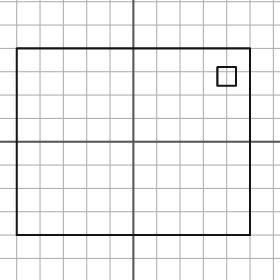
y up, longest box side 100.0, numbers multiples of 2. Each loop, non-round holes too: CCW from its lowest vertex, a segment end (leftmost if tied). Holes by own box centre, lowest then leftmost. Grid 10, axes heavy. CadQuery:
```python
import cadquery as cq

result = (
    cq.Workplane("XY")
    .moveTo(-50.0, -40.0)
    .lineTo(50.0, -40.0)
    .lineTo(50.0, 40.0)
    .lineTo(-50.0, 40.0)
    .close()
    .moveTo(36.0, 24.0)
    .lineTo(44.0, 24.0)
    .lineTo(44.0, 32.0)
    .lineTo(36.0, 32.0)
    .close()
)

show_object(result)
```